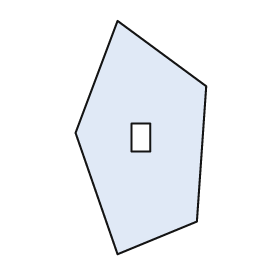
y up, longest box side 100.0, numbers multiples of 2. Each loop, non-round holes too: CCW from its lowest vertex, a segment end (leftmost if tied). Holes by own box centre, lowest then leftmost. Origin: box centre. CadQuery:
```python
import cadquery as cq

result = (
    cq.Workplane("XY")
    .moveTo(-10.0, -50.0)
    .lineTo(24.0, -36.0)
    .lineTo(28.0, 22.0)
    .lineTo(-10.0, 50.0)
    .lineTo(-28.0, 2.0)
    .close()
    .moveTo(-4.0, -6.0)
    .lineTo(4.0, -6.0)
    .lineTo(4.0, 6.0)
    .lineTo(-4.0, 6.0)
    .close()
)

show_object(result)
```